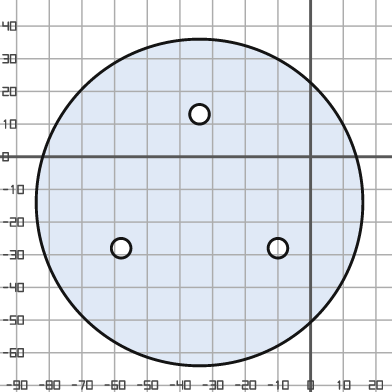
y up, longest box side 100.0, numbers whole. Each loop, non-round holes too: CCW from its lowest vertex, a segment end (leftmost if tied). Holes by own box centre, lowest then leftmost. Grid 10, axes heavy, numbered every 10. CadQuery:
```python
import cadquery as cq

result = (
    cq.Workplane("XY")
    .moveTo(-34.0, -14.0)
    .circle(50.0)
    .moveTo(-58.0, -28.0)
    .circle(3.0)
    .moveTo(-10.0, -28.0)
    .circle(3.0)
    .moveTo(-34.0, 13.0)
    .circle(3.0)
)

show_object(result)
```